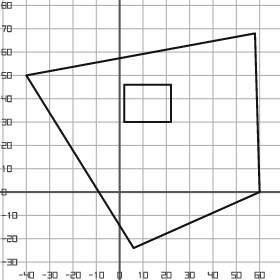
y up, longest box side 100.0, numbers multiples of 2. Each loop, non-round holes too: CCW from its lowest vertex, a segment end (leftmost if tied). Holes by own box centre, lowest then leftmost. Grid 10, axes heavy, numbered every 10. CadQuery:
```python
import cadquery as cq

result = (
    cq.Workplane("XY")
    .moveTo(6.0, -24.0)
    .lineTo(60.0, 0.0)
    .lineTo(58.0, 68.0)
    .lineTo(-40.0, 50.0)
    .close()
    .moveTo(2.0, 30.0)
    .lineTo(22.0, 30.0)
    .lineTo(22.0, 46.0)
    .lineTo(2.0, 46.0)
    .close()
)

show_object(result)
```